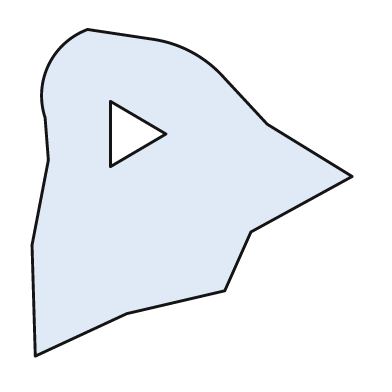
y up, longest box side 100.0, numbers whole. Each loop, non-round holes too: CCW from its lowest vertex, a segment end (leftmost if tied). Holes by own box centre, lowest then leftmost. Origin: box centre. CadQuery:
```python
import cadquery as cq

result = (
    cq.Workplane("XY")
    .moveTo(-48.0, -50.0)
    .lineTo(-20.0, -37.0)
    .lineTo(10.0, -30.0)
    .lineTo(18.0, -12.0)
    .lineTo(49.0, 5.0)
    .lineTo(23.0, 21.0)
    .lineTo(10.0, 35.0)
    .threePointArc((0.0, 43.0), (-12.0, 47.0))
    .lineTo(-32.0, 50.0)
    .threePointArc((-44.0, 39.0), (-45.0, 23.0))
    .lineTo(-44.0, 10.0)
    .lineTo(-49.0, -16.0)
    .close()
    .moveTo(-25.0, 8.0)
    .lineTo(-8.0, 18.0)
    .lineTo(-25.0, 28.0)
    .close()
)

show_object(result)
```